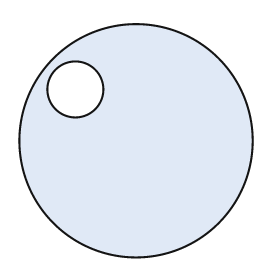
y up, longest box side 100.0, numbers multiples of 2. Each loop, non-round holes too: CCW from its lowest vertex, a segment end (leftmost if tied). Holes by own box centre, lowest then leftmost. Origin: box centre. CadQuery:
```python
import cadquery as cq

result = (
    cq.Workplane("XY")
    .moveTo(0.0, 0.0)
    .circle(50.0)
    .moveTo(-26.0, 22.0)
    .circle(12.0)
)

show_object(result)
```